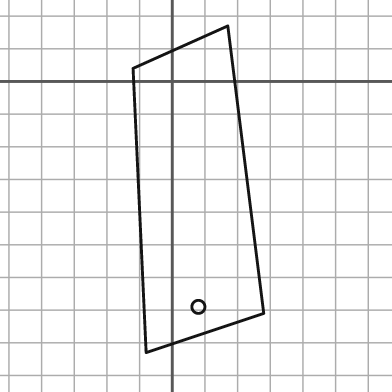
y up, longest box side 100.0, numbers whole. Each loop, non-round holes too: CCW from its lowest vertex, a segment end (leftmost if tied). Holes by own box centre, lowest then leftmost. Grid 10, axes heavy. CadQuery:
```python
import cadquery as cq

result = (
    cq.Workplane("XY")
    .moveTo(-8.0, -83.0)
    .lineTo(28.0, -71.0)
    .lineTo(17.0, 17.0)
    .lineTo(-12.0, 4.0)
    .close()
    .moveTo(8.0, -69.0)
    .circle(2.0)
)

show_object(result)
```